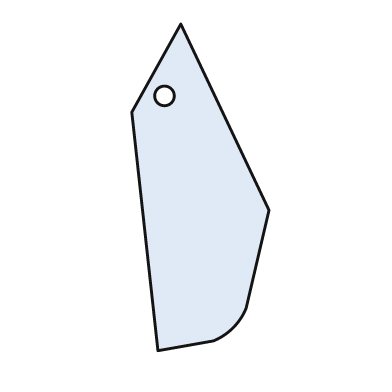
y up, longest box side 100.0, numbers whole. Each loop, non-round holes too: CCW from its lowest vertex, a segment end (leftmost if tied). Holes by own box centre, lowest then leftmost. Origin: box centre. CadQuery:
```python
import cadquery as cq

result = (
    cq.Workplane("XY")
    .moveTo(-13.0, -50.0)
    .lineTo(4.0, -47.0)
    .threePointArc((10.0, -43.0), (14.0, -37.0))
    .lineTo(21.0, -7.0)
    .lineTo(-6.0, 50.0)
    .lineTo(-21.0, 23.0)
    .close()
    .moveTo(-11.0, 28.0)
    .circle(3.0)
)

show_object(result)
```